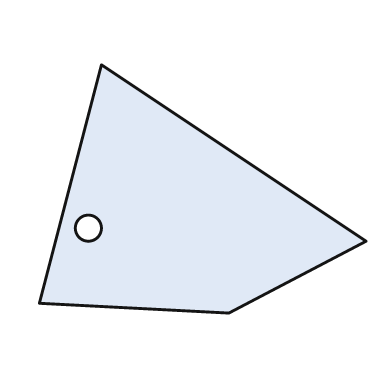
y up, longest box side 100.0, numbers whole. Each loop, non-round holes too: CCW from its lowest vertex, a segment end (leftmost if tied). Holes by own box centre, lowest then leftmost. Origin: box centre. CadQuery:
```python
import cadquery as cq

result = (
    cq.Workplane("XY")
    .moveTo(8.0, -38.0)
    .lineTo(50.0, -16.0)
    .lineTo(-31.0, 38.0)
    .lineTo(-50.0, -35.0)
    .close()
    .moveTo(-35.0, -12.0)
    .circle(4.0)
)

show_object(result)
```